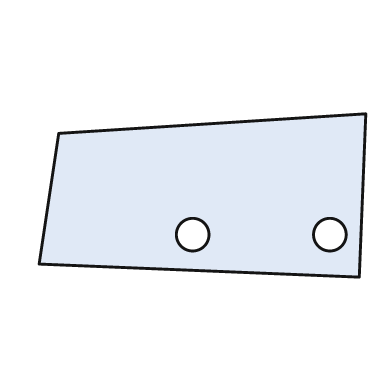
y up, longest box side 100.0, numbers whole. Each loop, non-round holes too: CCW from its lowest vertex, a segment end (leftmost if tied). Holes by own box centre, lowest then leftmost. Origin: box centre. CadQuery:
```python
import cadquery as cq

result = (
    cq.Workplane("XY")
    .moveTo(48.0, -25.0)
    .lineTo(50.0, 25.0)
    .lineTo(-44.0, 19.0)
    .lineTo(-50.0, -21.0)
    .close()
    .moveTo(-3.0, -12.0)
    .circle(5.0)
    .moveTo(39.0, -12.0)
    .circle(5.0)
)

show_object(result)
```